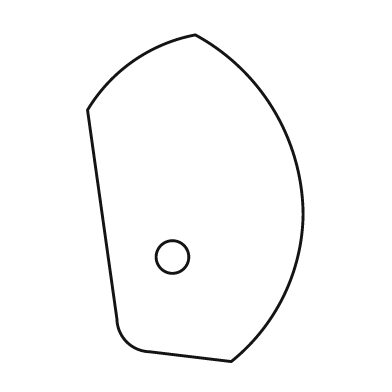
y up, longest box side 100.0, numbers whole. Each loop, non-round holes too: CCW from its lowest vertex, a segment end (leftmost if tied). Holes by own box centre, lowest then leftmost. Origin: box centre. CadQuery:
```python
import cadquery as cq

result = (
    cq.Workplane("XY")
    .moveTo(11.0, -50.0)
    .threePointArc((27.0, -30.0), (33.0, -5.0))
    .threePointArc((24.0, 27.0), (0.0, 50.0))
    .threePointArc((-19.0, 42.0), (-33.0, 27.0))
    .lineTo(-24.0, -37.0)
    .threePointArc((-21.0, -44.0), (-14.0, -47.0))
    .close()
    .moveTo(-7.0, -18.0)
    .circle(5.0)
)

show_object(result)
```